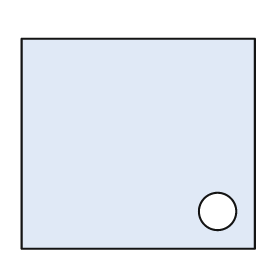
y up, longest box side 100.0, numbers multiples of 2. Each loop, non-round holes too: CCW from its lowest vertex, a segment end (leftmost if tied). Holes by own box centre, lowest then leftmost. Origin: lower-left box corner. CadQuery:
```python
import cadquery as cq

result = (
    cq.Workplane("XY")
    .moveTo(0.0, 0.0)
    .lineTo(100.0, 0.0)
    .lineTo(100.0, 90.0)
    .lineTo(0.0, 90.0)
    .close()
    .moveTo(84.0, 16.0)
    .circle(8.0)
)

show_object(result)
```